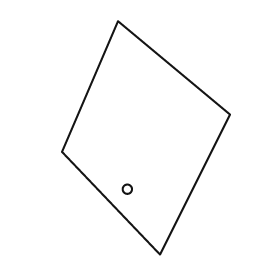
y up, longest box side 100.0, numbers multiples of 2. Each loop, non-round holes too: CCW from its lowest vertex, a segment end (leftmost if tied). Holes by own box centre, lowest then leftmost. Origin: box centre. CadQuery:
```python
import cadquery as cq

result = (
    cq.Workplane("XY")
    .moveTo(6.0, -50.0)
    .lineTo(36.0, 10.0)
    .lineTo(-12.0, 50.0)
    .lineTo(-36.0, -6.0)
    .close()
    .moveTo(-8.0, -22.0)
    .circle(2.0)
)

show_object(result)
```